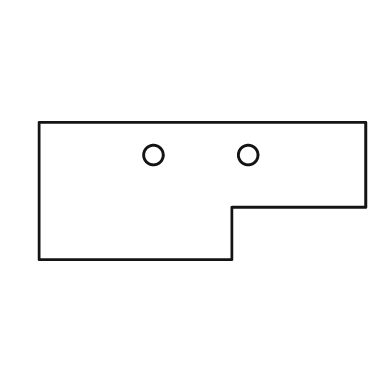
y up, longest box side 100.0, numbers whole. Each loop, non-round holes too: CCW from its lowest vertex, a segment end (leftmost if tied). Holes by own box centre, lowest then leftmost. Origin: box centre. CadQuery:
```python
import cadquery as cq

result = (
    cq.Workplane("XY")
    .moveTo(-50.0, -21.0)
    .lineTo(9.0, -21.0)
    .lineTo(9.0, -5.0)
    .lineTo(50.0, -5.0)
    .lineTo(50.0, 21.0)
    .lineTo(-50.0, 21.0)
    .close()
    .moveTo(-15.0, 11.0)
    .circle(3.0)
    .moveTo(14.0, 11.0)
    .circle(3.0)
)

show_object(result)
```